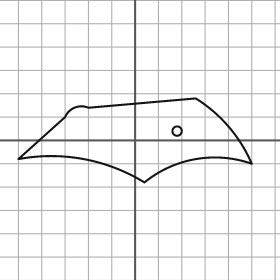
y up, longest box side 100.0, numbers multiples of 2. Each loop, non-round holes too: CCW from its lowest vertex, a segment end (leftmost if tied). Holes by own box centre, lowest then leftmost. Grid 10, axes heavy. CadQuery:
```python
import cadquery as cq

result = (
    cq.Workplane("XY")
    .moveTo(4.0, -18.0)
    .threePointArc((26.0, -8.0), (50.0, -10.0))
    .threePointArc((40.0, 6.0), (26.0, 18.0))
    .lineTo(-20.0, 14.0)
    .threePointArc((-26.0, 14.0), (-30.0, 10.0))
    .lineTo(-50.0, -8.0)
    .threePointArc((-22.0, -8.0), (4.0, -18.0))
    .close()
    .moveTo(18.0, 4.0)
    .circle(2.0)
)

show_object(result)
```